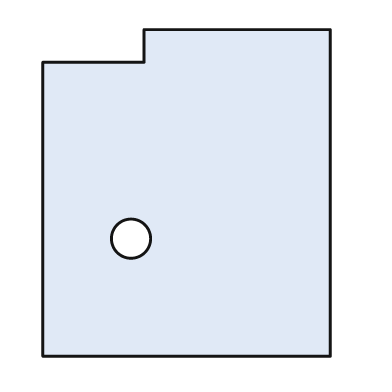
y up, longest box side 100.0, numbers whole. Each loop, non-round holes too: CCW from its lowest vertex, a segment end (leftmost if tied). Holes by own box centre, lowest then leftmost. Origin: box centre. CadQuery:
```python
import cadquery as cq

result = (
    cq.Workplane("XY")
    .moveTo(-44.0, -50.0)
    .lineTo(44.0, -50.0)
    .lineTo(44.0, 50.0)
    .lineTo(-13.0, 50.0)
    .lineTo(-13.0, 40.0)
    .lineTo(-44.0, 40.0)
    .close()
    .moveTo(-17.0, -14.0)
    .circle(6.0)
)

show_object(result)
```